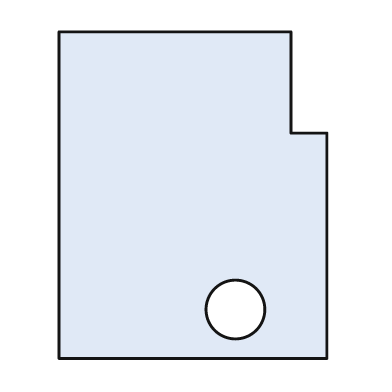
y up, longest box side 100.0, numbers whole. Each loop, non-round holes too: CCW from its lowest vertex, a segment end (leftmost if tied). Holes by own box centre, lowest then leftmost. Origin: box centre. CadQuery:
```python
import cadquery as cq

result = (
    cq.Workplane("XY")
    .moveTo(-41.0, -50.0)
    .lineTo(41.0, -50.0)
    .lineTo(41.0, 19.0)
    .lineTo(30.0, 19.0)
    .lineTo(30.0, 50.0)
    .lineTo(-41.0, 50.0)
    .close()
    .moveTo(13.0, -35.0)
    .circle(9.0)
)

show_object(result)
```